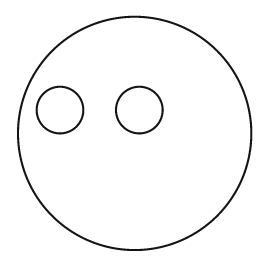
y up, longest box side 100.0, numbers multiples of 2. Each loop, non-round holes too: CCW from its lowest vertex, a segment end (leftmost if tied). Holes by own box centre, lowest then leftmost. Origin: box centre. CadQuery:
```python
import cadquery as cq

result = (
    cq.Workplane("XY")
    .moveTo(0.0, 0.0)
    .circle(50.0)
    .moveTo(-32.0, 10.0)
    .circle(10.0)
    .moveTo(2.0, 10.0)
    .circle(10.0)
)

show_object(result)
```